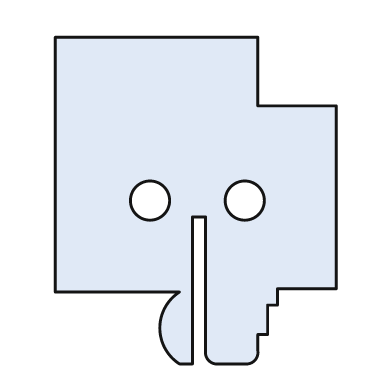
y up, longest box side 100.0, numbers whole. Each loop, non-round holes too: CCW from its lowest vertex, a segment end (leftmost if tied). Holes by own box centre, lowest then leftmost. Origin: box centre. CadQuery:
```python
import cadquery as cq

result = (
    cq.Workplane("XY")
    .moveTo(-5.0, -50.0)
    .lineTo(-1.0, -50.0)
    .lineTo(-1.0, -5.0)
    .lineTo(3.0, -5.0)
    .lineTo(3.0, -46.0)
    .threePointArc((4.0, -49.0), (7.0, -50.0))
    .lineTo(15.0, -50.0)
    .threePointArc((18.0, -49.0), (19.0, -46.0))
    .lineTo(19.0, -41.0)
    .lineTo(22.0, -41.0)
    .lineTo(22.0, -32.0)
    .lineTo(25.0, -32.0)
    .lineTo(25.0, -27.0)
    .lineTo(43.0, -27.0)
    .lineTo(43.0, 29.0)
    .lineTo(19.0, 29.0)
    .lineTo(19.0, 50.0)
    .lineTo(-43.0, 50.0)
    .lineTo(-43.0, -28.0)
    .lineTo(-5.0, -28.0)
    .threePointArc((-11.0, -39.0), (-5.0, -50.0))
    .close()
    .moveTo(-14.0, 0.0)
    .circle(6.0)
    .moveTo(15.0, 0.0)
    .circle(6.0)
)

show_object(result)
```